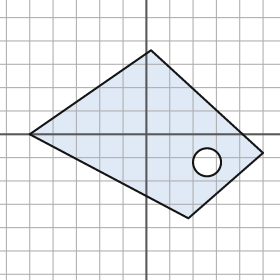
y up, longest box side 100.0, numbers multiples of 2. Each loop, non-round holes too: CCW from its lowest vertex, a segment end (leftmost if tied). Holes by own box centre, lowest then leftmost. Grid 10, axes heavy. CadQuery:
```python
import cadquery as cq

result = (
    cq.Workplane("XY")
    .moveTo(18.0, -36.0)
    .lineTo(50.0, -8.0)
    .lineTo(2.0, 36.0)
    .lineTo(-50.0, 0.0)
    .close()
    .moveTo(26.0, -12.0)
    .circle(6.0)
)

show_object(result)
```